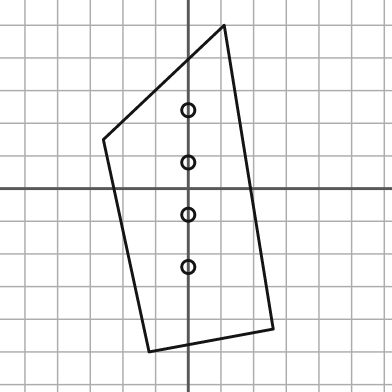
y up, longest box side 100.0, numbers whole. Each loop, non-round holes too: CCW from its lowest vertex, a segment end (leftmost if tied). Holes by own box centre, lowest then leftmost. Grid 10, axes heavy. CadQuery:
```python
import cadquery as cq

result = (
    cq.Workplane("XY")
    .moveTo(-12.0, -50.0)
    .lineTo(26.0, -43.0)
    .lineTo(11.0, 50.0)
    .lineTo(-26.0, 15.0)
    .close()
    .moveTo(0.0, -24.0)
    .circle(2.0)
    .moveTo(0.0, -8.0)
    .circle(2.0)
    .moveTo(0.0, 8.0)
    .circle(2.0)
    .moveTo(0.0, 24.0)
    .circle(2.0)
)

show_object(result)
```